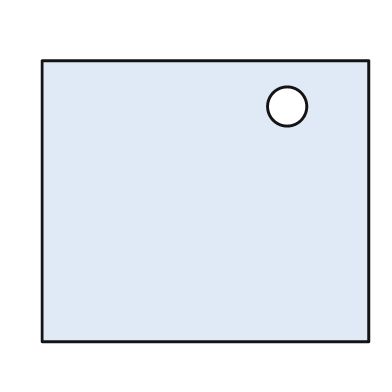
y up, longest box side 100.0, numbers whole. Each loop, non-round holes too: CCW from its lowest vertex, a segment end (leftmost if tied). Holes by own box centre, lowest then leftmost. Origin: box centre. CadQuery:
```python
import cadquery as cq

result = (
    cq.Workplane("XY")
    .moveTo(-50.0, -43.0)
    .lineTo(50.0, -43.0)
    .lineTo(50.0, 43.0)
    .lineTo(-50.0, 43.0)
    .close()
    .moveTo(25.0, 29.0)
    .circle(6.0)
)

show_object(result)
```